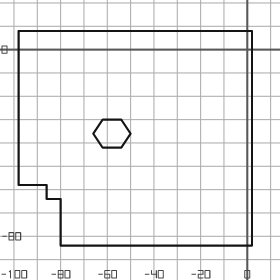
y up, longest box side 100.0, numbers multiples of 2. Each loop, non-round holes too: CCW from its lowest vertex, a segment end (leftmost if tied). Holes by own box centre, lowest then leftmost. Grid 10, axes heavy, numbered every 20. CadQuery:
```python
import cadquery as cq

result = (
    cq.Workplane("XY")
    .moveTo(-80.0, -84.0)
    .lineTo(2.0, -84.0)
    .lineTo(2.0, 8.0)
    .lineTo(-98.0, 8.0)
    .lineTo(-98.0, -58.0)
    .lineTo(-86.0, -58.0)
    .lineTo(-86.0, -64.0)
    .lineTo(-80.0, -64.0)
    .close()
    .moveTo(-62.0, -42.0)
    .lineTo(-54.0, -42.0)
    .lineTo(-50.0, -36.0)
    .lineTo(-54.0, -30.0)
    .lineTo(-62.0, -30.0)
    .lineTo(-66.0, -36.0)
    .close()
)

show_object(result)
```